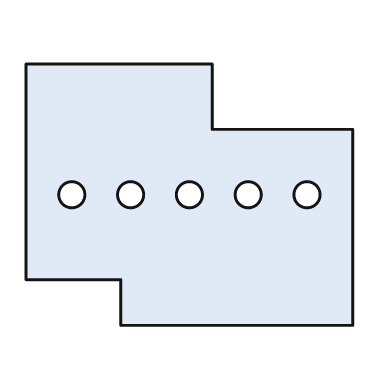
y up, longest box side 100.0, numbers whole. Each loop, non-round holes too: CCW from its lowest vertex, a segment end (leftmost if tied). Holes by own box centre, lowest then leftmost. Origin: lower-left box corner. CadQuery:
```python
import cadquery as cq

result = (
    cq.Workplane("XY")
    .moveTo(29.0, 0.0)
    .lineTo(100.0, 0.0)
    .lineTo(100.0, 60.0)
    .lineTo(57.0, 60.0)
    .lineTo(57.0, 80.0)
    .lineTo(0.0, 80.0)
    .lineTo(0.0, 14.0)
    .lineTo(29.0, 14.0)
    .close()
    .moveTo(14.0, 40.0)
    .circle(4.0)
    .moveTo(32.0, 40.0)
    .circle(4.0)
    .moveTo(50.0, 40.0)
    .circle(4.0)
    .moveTo(68.0, 40.0)
    .circle(4.0)
    .moveTo(86.0, 40.0)
    .circle(4.0)
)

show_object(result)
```